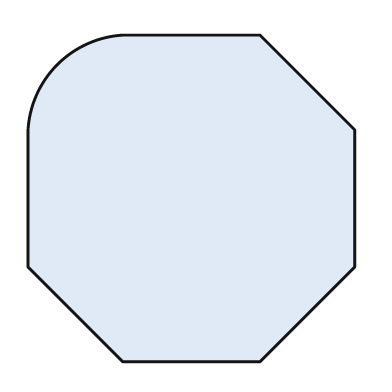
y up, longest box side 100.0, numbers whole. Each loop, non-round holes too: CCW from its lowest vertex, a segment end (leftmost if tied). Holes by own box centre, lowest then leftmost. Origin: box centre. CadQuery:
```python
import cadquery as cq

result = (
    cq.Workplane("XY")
    .moveTo(-21.0, -50.0)
    .lineTo(21.0, -50.0)
    .lineTo(50.0, -21.0)
    .lineTo(50.0, 21.0)
    .lineTo(21.0, 50.0)
    .lineTo(-21.0, 50.0)
    .threePointArc((-41.0, 41.0), (-50.0, 21.0))
    .lineTo(-50.0, -21.0)
    .close()
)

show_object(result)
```